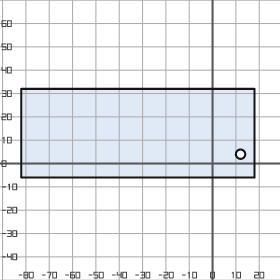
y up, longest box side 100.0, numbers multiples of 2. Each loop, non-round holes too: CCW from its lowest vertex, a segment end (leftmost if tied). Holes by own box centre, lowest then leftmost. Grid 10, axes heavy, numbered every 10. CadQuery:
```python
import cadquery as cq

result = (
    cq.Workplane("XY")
    .moveTo(-82.0, -6.0)
    .lineTo(18.0, -6.0)
    .lineTo(18.0, 32.0)
    .lineTo(-82.0, 32.0)
    .close()
    .moveTo(12.0, 4.0)
    .circle(2.0)
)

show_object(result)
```